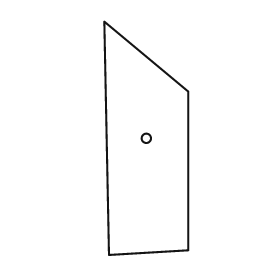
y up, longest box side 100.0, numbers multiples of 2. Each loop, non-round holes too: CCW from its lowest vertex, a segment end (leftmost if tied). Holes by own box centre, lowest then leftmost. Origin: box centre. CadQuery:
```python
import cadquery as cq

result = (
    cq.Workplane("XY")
    .moveTo(-16.0, -50.0)
    .lineTo(18.0, -48.0)
    .lineTo(18.0, 20.0)
    .lineTo(-18.0, 50.0)
    .close()
    .moveTo(0.0, 0.0)
    .circle(2.0)
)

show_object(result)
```